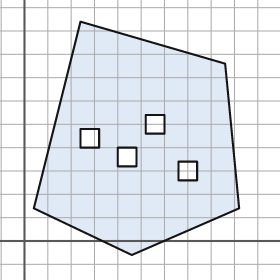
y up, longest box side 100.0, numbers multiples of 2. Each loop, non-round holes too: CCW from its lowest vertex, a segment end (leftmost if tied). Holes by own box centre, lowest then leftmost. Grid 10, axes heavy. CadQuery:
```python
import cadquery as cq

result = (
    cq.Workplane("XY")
    .moveTo(46.0, -6.0)
    .lineTo(92.0, 14.0)
    .lineTo(86.0, 76.0)
    .lineTo(24.0, 94.0)
    .lineTo(4.0, 14.0)
    .close()
    .moveTo(66.0, 26.0)
    .lineTo(74.0, 26.0)
    .lineTo(74.0, 34.0)
    .lineTo(66.0, 34.0)
    .close()
    .moveTo(40.0, 32.0)
    .lineTo(48.0, 32.0)
    .lineTo(48.0, 40.0)
    .lineTo(40.0, 40.0)
    .close()
    .moveTo(24.0, 40.0)
    .lineTo(32.0, 40.0)
    .lineTo(32.0, 48.0)
    .lineTo(24.0, 48.0)
    .close()
    .moveTo(52.0, 46.0)
    .lineTo(60.0, 46.0)
    .lineTo(60.0, 54.0)
    .lineTo(52.0, 54.0)
    .close()
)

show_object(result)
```